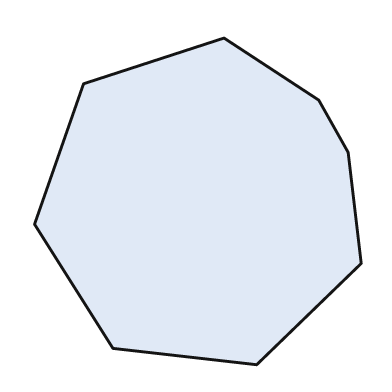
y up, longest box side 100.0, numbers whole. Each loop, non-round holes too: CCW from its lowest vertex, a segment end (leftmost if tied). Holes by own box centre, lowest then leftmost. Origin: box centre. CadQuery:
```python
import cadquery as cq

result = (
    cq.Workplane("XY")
    .moveTo(18.0, -50.0)
    .lineTo(50.0, -19.0)
    .lineTo(46.0, 15.0)
    .lineTo(37.0, 31.0)
    .lineTo(8.0, 50.0)
    .lineTo(-35.0, 36.0)
    .lineTo(-50.0, -7.0)
    .lineTo(-26.0, -45.0)
    .close()
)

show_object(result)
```